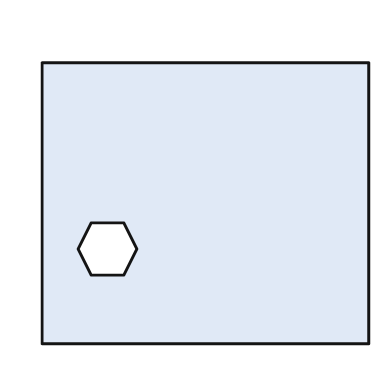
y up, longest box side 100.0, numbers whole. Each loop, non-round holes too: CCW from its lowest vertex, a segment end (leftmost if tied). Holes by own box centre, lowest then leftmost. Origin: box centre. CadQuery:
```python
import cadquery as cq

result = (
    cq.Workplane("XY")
    .moveTo(-50.0, -43.0)
    .lineTo(50.0, -43.0)
    .lineTo(50.0, 43.0)
    .lineTo(-50.0, 43.0)
    .close()
    .moveTo(-35.0, -22.0)
    .lineTo(-25.0, -22.0)
    .lineTo(-21.0, -14.0)
    .lineTo(-25.0, -6.0)
    .lineTo(-35.0, -6.0)
    .lineTo(-39.0, -14.0)
    .close()
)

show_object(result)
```